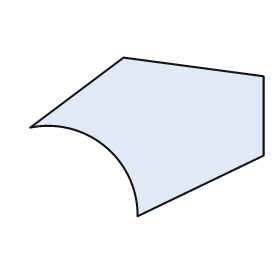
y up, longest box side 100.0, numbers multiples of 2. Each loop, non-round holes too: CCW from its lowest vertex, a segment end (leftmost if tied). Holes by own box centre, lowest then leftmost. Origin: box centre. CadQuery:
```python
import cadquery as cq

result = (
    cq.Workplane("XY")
    .moveTo(-4.0, -34.0)
    .lineTo(50.0, -8.0)
    .lineTo(50.0, 26.0)
    .lineTo(-10.0, 34.0)
    .lineTo(-50.0, 4.0)
    .threePointArc((-18.0, -4.0), (-4.0, -34.0))
    .close()
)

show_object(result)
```